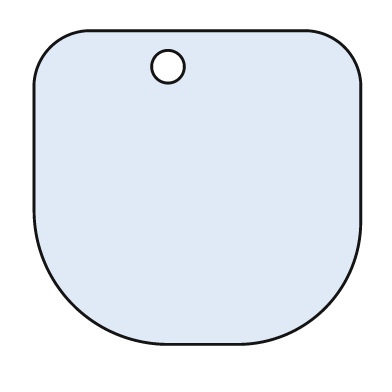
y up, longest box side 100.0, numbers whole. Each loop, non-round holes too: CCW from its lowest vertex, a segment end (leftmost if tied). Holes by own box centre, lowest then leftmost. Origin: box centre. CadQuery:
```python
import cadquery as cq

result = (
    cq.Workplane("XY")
    .moveTo(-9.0, -48.0)
    .lineTo(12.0, -48.0)
    .threePointArc((39.0, -37.0), (50.0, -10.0))
    .lineTo(50.0, 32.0)
    .threePointArc((45.0, 43.0), (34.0, 48.0))
    .lineTo(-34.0, 48.0)
    .threePointArc((-45.0, 43.0), (-50.0, 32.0))
    .lineTo(-50.0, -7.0)
    .threePointArc((-38.0, -36.0), (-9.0, -48.0))
    .close()
    .moveTo(-9.0, 37.0)
    .circle(5.0)
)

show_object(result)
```